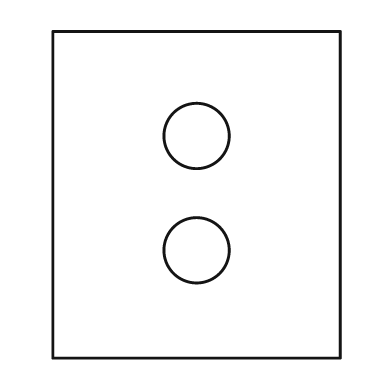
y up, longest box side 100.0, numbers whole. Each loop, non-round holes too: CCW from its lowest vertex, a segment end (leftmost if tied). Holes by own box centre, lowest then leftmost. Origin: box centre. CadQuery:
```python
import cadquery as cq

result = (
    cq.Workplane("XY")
    .moveTo(-44.0, -50.0)
    .lineTo(44.0, -50.0)
    .lineTo(44.0, 50.0)
    .lineTo(-44.0, 50.0)
    .close()
    .moveTo(0.0, -17.0)
    .circle(10.0)
    .moveTo(0.0, 18.0)
    .circle(10.0)
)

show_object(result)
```